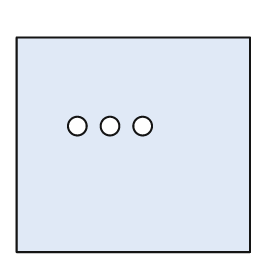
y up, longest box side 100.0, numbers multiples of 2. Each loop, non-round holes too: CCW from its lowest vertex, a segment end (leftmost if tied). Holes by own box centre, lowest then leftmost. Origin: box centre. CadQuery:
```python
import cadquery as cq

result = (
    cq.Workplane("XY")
    .moveTo(-50.0, -46.0)
    .lineTo(50.0, -46.0)
    .lineTo(50.0, 46.0)
    .lineTo(-50.0, 46.0)
    .close()
    .moveTo(-24.0, 8.0)
    .circle(4.0)
    .moveTo(-10.0, 8.0)
    .circle(4.0)
    .moveTo(4.0, 8.0)
    .circle(4.0)
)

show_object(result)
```